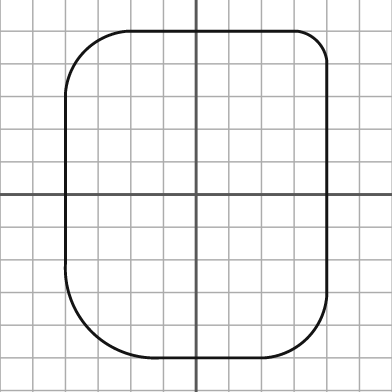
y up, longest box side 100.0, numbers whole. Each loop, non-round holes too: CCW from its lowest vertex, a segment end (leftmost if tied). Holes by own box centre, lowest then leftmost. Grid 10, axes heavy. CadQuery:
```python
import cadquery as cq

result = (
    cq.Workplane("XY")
    .moveTo(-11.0, -50.0)
    .lineTo(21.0, -50.0)
    .threePointArc((34.0, -44.0), (40.0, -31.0))
    .lineTo(40.0, 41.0)
    .threePointArc((37.0, 47.0), (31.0, 50.0))
    .lineTo(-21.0, 50.0)
    .threePointArc((-34.0, 44.0), (-40.0, 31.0))
    .lineTo(-40.0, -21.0)
    .threePointArc((-32.0, -42.0), (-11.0, -50.0))
    .close()
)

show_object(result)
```